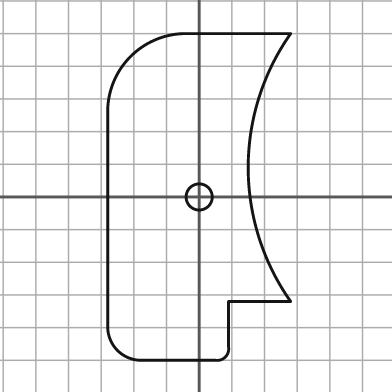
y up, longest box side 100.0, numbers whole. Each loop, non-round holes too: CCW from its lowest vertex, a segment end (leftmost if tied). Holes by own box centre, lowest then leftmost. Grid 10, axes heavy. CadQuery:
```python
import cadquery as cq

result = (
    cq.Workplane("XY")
    .moveTo(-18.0, -50.0)
    .lineTo(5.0, -50.0)
    .threePointArc((8.0, -49.0), (9.0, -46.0))
    .lineTo(9.0, -32.0)
    .lineTo(28.0, -32.0)
    .threePointArc((15.0, 9.0), (28.0, 50.0))
    .lineTo(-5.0, 50.0)
    .threePointArc((-21.0, 43.0), (-28.0, 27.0))
    .lineTo(-28.0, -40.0)
    .threePointArc((-25.0, -47.0), (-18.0, -50.0))
    .close()
    .moveTo(0.0, 0.0)
    .circle(4.0)
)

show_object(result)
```